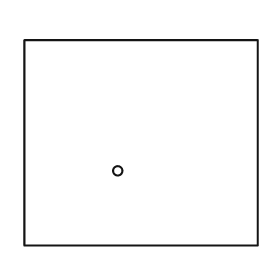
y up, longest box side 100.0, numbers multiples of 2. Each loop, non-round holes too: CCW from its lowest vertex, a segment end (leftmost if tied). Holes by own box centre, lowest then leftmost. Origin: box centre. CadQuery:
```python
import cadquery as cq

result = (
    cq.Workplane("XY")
    .moveTo(-50.0, -44.0)
    .lineTo(50.0, -44.0)
    .lineTo(50.0, 44.0)
    .lineTo(-50.0, 44.0)
    .close()
    .moveTo(-10.0, -12.0)
    .circle(2.0)
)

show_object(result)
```